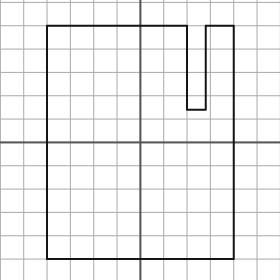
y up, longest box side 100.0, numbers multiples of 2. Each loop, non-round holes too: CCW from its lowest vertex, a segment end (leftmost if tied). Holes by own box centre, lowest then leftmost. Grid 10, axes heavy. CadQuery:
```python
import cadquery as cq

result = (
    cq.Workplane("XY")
    .moveTo(-40.0, -50.0)
    .lineTo(40.0, -50.0)
    .lineTo(40.0, 50.0)
    .lineTo(28.0, 50.0)
    .lineTo(28.0, 14.0)
    .lineTo(20.0, 14.0)
    .lineTo(20.0, 50.0)
    .lineTo(-40.0, 50.0)
    .close()
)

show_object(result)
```